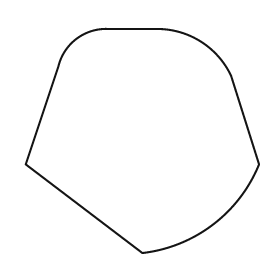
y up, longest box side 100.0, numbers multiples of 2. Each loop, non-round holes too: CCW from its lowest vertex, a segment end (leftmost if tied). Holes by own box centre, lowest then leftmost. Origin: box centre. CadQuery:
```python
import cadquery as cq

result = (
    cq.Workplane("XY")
    .moveTo(0.0, -48.0)
    .threePointArc((30.0, -36.0), (50.0, -10.0))
    .lineTo(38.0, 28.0)
    .threePointArc((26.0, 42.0), (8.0, 48.0))
    .lineTo(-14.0, 48.0)
    .threePointArc((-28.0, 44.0), (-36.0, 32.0))
    .lineTo(-50.0, -10.0)
    .close()
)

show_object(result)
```